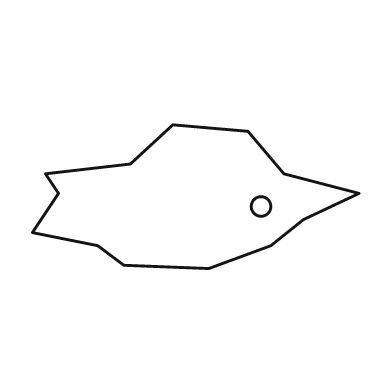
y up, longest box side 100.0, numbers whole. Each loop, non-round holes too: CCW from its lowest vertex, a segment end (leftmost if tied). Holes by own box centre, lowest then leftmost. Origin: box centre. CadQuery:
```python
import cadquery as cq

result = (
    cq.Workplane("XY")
    .moveTo(4.0, -22.0)
    .lineTo(23.0, -15.0)
    .lineTo(33.0, -7.0)
    .lineTo(50.0, 1.0)
    .lineTo(27.0, 7.0)
    .lineTo(16.0, 20.0)
    .lineTo(-7.0, 22.0)
    .lineTo(-20.0, 10.0)
    .lineTo(-46.0, 7.0)
    .lineTo(-42.0, 1.0)
    .lineTo(-50.0, -11.0)
    .lineTo(-30.0, -15.0)
    .lineTo(-22.0, -21.0)
    .close()
    .moveTo(20.0, -3.0)
    .circle(3.0)
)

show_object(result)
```